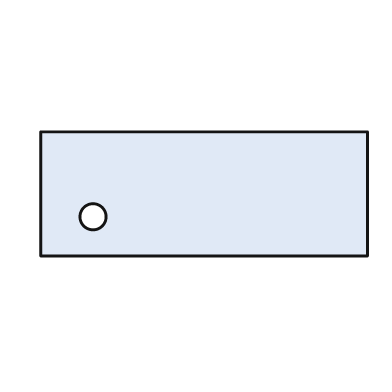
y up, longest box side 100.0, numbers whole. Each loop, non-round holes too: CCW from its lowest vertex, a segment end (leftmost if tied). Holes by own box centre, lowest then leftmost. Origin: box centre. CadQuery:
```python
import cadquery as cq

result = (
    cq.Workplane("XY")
    .moveTo(-50.0, -19.0)
    .lineTo(50.0, -19.0)
    .lineTo(50.0, 19.0)
    .lineTo(-50.0, 19.0)
    .close()
    .moveTo(-34.0, -7.0)
    .circle(4.0)
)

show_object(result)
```